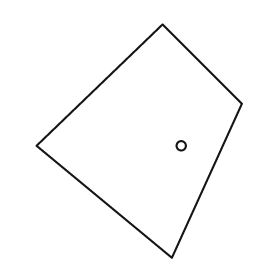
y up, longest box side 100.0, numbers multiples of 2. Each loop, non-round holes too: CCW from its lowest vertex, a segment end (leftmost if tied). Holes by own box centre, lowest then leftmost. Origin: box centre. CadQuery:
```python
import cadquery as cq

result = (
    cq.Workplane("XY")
    .moveTo(14.0, -50.0)
    .lineTo(44.0, 16.0)
    .lineTo(10.0, 50.0)
    .lineTo(-44.0, -2.0)
    .close()
    .moveTo(18.0, -2.0)
    .circle(2.0)
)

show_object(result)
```